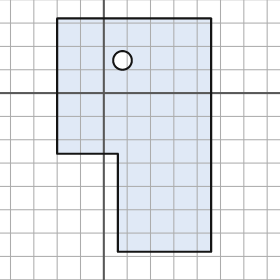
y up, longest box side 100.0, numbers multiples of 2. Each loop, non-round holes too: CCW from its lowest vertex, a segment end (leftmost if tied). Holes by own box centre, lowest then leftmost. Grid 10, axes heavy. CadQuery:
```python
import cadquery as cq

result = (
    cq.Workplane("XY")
    .moveTo(6.0, -68.0)
    .lineTo(46.0, -68.0)
    .lineTo(46.0, 32.0)
    .lineTo(-20.0, 32.0)
    .lineTo(-20.0, -26.0)
    .lineTo(6.0, -26.0)
    .close()
    .moveTo(8.0, 14.0)
    .circle(4.0)
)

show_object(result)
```